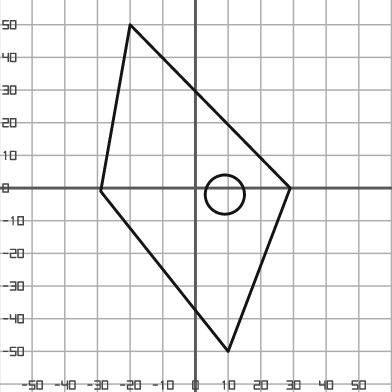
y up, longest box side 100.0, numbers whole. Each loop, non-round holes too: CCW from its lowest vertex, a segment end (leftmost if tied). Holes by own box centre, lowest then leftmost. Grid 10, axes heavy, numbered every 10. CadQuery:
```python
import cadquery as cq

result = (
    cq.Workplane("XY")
    .moveTo(10.0, -50.0)
    .lineTo(29.0, 0.0)
    .lineTo(-20.0, 50.0)
    .lineTo(-29.0, -1.0)
    .close()
    .moveTo(9.0, -2.0)
    .circle(6.0)
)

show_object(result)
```